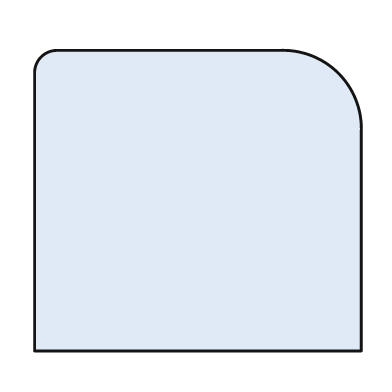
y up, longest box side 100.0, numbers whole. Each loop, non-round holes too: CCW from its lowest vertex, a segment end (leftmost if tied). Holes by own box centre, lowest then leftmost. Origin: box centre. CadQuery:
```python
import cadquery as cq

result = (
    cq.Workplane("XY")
    .moveTo(-50.0, -46.0)
    .lineTo(50.0, -46.0)
    .lineTo(50.0, 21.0)
    .threePointArc((43.0, 39.0), (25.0, 46.0))
    .lineTo(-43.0, 46.0)
    .threePointArc((-48.0, 44.0), (-50.0, 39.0))
    .close()
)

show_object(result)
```